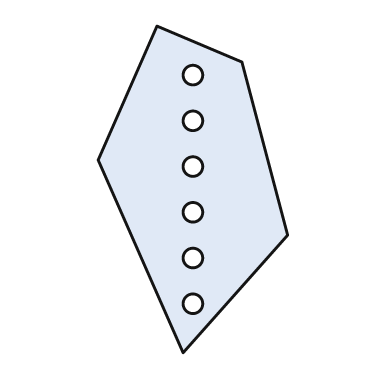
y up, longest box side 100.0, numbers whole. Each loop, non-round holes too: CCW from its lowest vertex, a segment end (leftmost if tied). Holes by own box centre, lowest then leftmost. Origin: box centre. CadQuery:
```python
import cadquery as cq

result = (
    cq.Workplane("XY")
    .moveTo(-3.0, -50.0)
    .lineTo(29.0, -14.0)
    .lineTo(15.0, 39.0)
    .lineTo(-11.0, 50.0)
    .lineTo(-29.0, 9.0)
    .close()
    .moveTo(0.0, -35.0)
    .circle(3.0)
    .moveTo(0.0, -21.0)
    .circle(3.0)
    .moveTo(0.0, -7.0)
    .circle(3.0)
    .moveTo(0.0, 7.0)
    .circle(3.0)
    .moveTo(0.0, 21.0)
    .circle(3.0)
    .moveTo(0.0, 35.0)
    .circle(3.0)
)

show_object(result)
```